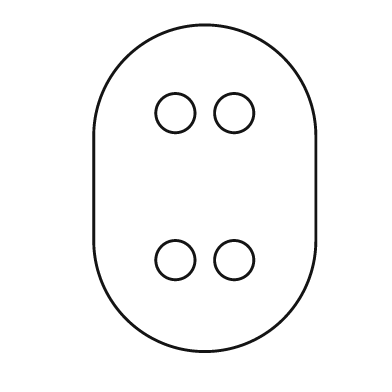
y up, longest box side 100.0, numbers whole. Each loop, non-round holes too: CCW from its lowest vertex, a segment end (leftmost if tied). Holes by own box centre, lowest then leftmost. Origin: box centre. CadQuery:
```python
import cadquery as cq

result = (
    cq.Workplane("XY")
    .moveTo(-34.0, -16.0)
    .threePointArc((0.0, -50.0), (34.0, -16.0))
    .lineTo(34.0, 16.0)
    .threePointArc((0.0, 50.0), (-34.0, 16.0))
    .close()
    .moveTo(-9.0, -22.0)
    .circle(6.0)
    .moveTo(9.0, -22.0)
    .circle(6.0)
    .moveTo(-9.0, 23.0)
    .circle(6.0)
    .moveTo(9.0, 23.0)
    .circle(6.0)
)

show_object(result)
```